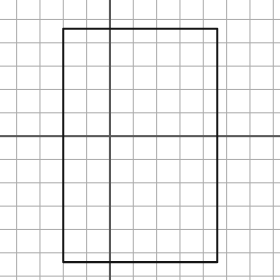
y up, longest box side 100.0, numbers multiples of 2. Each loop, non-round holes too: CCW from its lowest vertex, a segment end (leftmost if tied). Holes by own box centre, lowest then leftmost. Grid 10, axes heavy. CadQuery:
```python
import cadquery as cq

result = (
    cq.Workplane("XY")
    .moveTo(-20.0, -54.0)
    .lineTo(46.0, -54.0)
    .lineTo(46.0, 46.0)
    .lineTo(-20.0, 46.0)
    .close()
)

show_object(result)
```